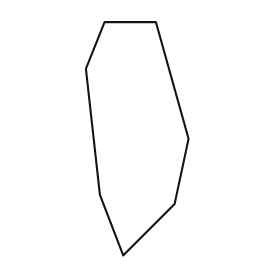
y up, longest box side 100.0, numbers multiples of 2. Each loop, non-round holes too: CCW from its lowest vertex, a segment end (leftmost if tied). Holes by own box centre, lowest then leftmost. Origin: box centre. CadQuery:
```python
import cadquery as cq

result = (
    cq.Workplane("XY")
    .moveTo(-6.0, -50.0)
    .lineTo(16.0, -28.0)
    .lineTo(22.0, 0.0)
    .lineTo(8.0, 50.0)
    .lineTo(-14.0, 50.0)
    .lineTo(-22.0, 30.0)
    .lineTo(-16.0, -24.0)
    .close()
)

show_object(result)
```